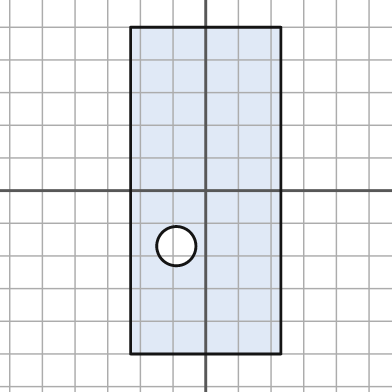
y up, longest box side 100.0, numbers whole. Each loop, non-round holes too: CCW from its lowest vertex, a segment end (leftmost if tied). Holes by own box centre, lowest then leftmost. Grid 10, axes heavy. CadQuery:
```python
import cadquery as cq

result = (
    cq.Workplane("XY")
    .moveTo(-23.0, -50.0)
    .lineTo(23.0, -50.0)
    .lineTo(23.0, 50.0)
    .lineTo(-23.0, 50.0)
    .close()
    .moveTo(-9.0, -17.0)
    .circle(6.0)
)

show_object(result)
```